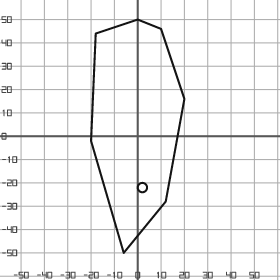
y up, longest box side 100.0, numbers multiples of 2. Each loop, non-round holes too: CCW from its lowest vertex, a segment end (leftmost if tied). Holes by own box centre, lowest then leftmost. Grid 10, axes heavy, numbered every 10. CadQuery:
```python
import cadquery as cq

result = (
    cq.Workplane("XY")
    .moveTo(-6.0, -50.0)
    .lineTo(12.0, -28.0)
    .lineTo(20.0, 16.0)
    .lineTo(10.0, 46.0)
    .lineTo(0.0, 50.0)
    .lineTo(-18.0, 44.0)
    .lineTo(-20.0, -2.0)
    .close()
    .moveTo(2.0, -22.0)
    .circle(2.0)
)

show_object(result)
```